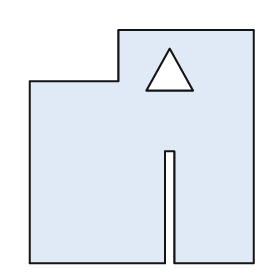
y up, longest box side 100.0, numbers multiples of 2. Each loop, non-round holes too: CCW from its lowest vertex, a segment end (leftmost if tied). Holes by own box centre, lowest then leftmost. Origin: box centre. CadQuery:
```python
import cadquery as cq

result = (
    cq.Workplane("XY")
    .moveTo(-48.0, -50.0)
    .lineTo(10.0, -50.0)
    .lineTo(10.0, -2.0)
    .lineTo(14.0, -2.0)
    .lineTo(14.0, -50.0)
    .lineTo(48.0, -50.0)
    .lineTo(48.0, 50.0)
    .lineTo(-10.0, 50.0)
    .lineTo(-10.0, 28.0)
    .lineTo(-48.0, 28.0)
    .close()
    .moveTo(2.0, 24.0)
    .lineTo(22.0, 24.0)
    .lineTo(12.0, 42.0)
    .close()
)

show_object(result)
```